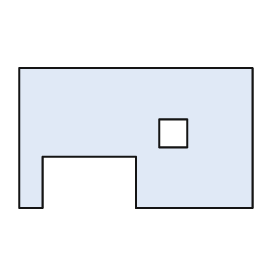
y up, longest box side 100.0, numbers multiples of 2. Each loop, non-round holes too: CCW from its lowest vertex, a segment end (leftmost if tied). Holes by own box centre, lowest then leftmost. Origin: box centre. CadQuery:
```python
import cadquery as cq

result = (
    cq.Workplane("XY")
    .moveTo(-50.0, -30.0)
    .lineTo(-40.0, -30.0)
    .lineTo(-40.0, -8.0)
    .lineTo(0.0, -8.0)
    .lineTo(0.0, -30.0)
    .lineTo(50.0, -30.0)
    .lineTo(50.0, 30.0)
    .lineTo(-50.0, 30.0)
    .close()
    .moveTo(10.0, -4.0)
    .lineTo(22.0, -4.0)
    .lineTo(22.0, 8.0)
    .lineTo(10.0, 8.0)
    .close()
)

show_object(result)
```